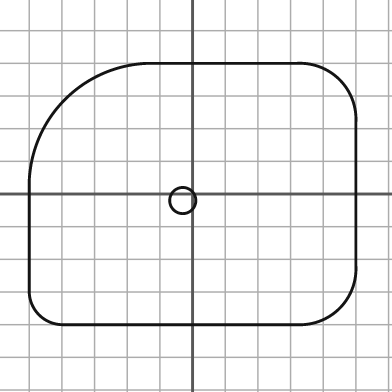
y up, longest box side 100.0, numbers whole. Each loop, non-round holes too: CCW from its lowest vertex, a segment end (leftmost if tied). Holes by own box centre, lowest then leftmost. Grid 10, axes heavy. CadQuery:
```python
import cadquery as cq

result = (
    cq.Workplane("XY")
    .moveTo(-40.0, -40.0)
    .lineTo(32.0, -40.0)
    .threePointArc((45.0, -35.0), (50.0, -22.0))
    .lineTo(50.0, 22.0)
    .threePointArc((45.0, 35.0), (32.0, 40.0))
    .lineTo(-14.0, 40.0)
    .threePointArc((-39.0, 29.0), (-50.0, 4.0))
    .lineTo(-50.0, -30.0)
    .threePointArc((-47.0, -37.0), (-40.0, -40.0))
    .close()
    .moveTo(-3.0, -2.0)
    .circle(4.0)
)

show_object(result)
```